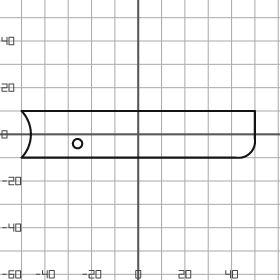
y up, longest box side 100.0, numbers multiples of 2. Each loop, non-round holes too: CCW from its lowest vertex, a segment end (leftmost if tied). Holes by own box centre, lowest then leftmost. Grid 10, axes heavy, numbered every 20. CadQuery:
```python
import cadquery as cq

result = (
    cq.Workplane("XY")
    .moveTo(-50.0, -10.0)
    .lineTo(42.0, -10.0)
    .threePointArc((48.0, -8.0), (50.0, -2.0))
    .lineTo(50.0, 10.0)
    .lineTo(-50.0, 10.0)
    .threePointArc((-46.0, 0.0), (-50.0, -10.0))
    .close()
    .moveTo(-26.0, -4.0)
    .circle(2.0)
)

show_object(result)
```